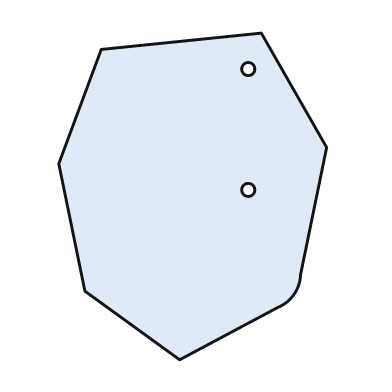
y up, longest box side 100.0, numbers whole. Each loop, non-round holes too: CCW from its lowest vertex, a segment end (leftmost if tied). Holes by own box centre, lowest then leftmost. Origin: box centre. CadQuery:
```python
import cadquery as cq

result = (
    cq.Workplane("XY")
    .moveTo(-4.0, -50.0)
    .lineTo(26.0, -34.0)
    .threePointArc((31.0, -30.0), (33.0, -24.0))
    .lineTo(41.0, 15.0)
    .lineTo(21.0, 50.0)
    .lineTo(-28.0, 45.0)
    .lineTo(-41.0, 10.0)
    .lineTo(-33.0, -29.0)
    .close()
    .moveTo(17.0, 2.0)
    .circle(2.0)
    .moveTo(17.0, 39.0)
    .circle(2.0)
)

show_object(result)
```